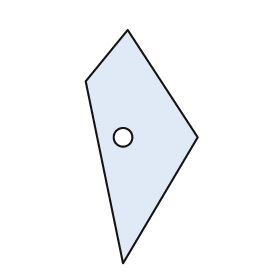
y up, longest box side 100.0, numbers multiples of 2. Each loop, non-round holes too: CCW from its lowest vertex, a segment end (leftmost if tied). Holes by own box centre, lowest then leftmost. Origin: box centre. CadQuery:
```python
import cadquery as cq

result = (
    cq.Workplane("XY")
    .moveTo(-8.0, -50.0)
    .lineTo(24.0, 4.0)
    .lineTo(-6.0, 50.0)
    .lineTo(-24.0, 28.0)
    .close()
    .moveTo(-8.0, 4.0)
    .circle(4.0)
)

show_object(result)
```